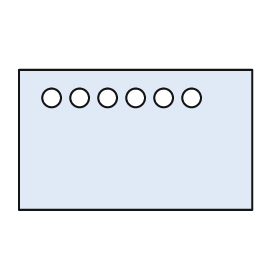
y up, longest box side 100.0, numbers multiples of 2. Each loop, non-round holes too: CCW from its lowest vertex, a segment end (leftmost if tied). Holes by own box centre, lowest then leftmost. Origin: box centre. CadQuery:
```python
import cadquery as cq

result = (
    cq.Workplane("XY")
    .moveTo(-50.0, -30.0)
    .lineTo(50.0, -30.0)
    .lineTo(50.0, 30.0)
    .lineTo(-50.0, 30.0)
    .close()
    .moveTo(-36.0, 18.0)
    .circle(4.0)
    .moveTo(-24.0, 18.0)
    .circle(4.0)
    .moveTo(-12.0, 18.0)
    .circle(4.0)
    .moveTo(0.0, 18.0)
    .circle(4.0)
    .moveTo(12.0, 18.0)
    .circle(4.0)
    .moveTo(24.0, 18.0)
    .circle(4.0)
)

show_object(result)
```